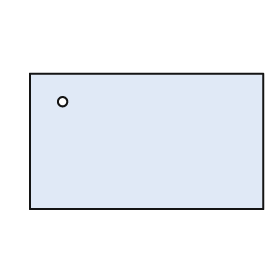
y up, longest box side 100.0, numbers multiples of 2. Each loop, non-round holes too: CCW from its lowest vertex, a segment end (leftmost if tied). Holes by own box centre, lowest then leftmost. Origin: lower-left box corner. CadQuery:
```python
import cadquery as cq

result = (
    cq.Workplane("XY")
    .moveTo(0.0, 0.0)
    .lineTo(100.0, 0.0)
    .lineTo(100.0, 58.0)
    .lineTo(0.0, 58.0)
    .close()
    .moveTo(14.0, 46.0)
    .circle(2.0)
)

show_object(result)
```